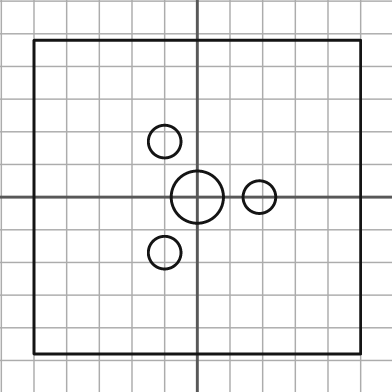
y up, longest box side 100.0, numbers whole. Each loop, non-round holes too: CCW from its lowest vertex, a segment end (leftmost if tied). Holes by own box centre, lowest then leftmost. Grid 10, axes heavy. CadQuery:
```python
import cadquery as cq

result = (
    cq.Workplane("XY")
    .moveTo(-50.0, -48.0)
    .lineTo(50.0, -48.0)
    .lineTo(50.0, 48.0)
    .lineTo(-50.0, 48.0)
    .close()
    .moveTo(-10.0, -17.0)
    .circle(5.0)
    .moveTo(0.0, 0.0)
    .circle(8.0)
    .moveTo(19.0, 0.0)
    .circle(5.0)
    .moveTo(-10.0, 17.0)
    .circle(5.0)
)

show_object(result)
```